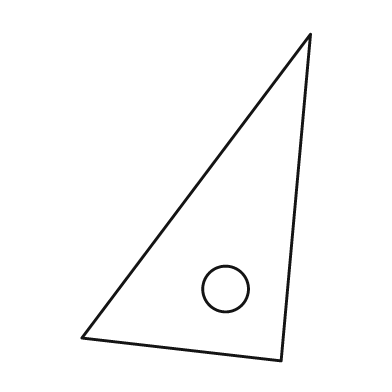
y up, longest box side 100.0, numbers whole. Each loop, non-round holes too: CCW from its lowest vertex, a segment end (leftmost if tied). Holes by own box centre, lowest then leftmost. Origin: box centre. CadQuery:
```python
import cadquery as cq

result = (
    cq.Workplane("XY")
    .moveTo(26.0, -50.0)
    .lineTo(35.0, 50.0)
    .lineTo(-35.0, -43.0)
    .close()
    .moveTo(9.0, -28.0)
    .circle(7.0)
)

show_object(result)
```